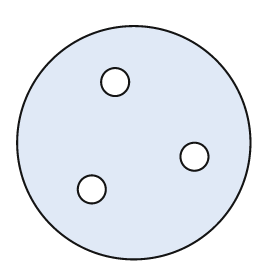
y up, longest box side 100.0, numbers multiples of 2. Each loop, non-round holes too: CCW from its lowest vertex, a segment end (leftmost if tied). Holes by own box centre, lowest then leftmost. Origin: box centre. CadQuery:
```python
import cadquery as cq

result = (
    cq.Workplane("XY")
    .moveTo(0.0, 0.0)
    .circle(50.0)
    .moveTo(-18.0, -20.0)
    .circle(6.0)
    .moveTo(26.0, -6.0)
    .circle(6.0)
    .moveTo(-8.0, 26.0)
    .circle(6.0)
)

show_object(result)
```